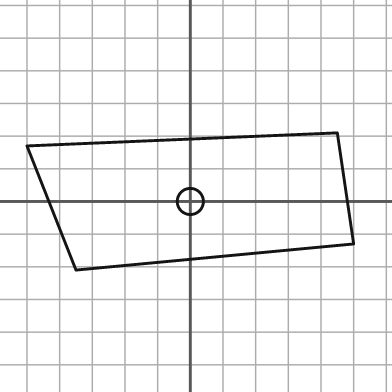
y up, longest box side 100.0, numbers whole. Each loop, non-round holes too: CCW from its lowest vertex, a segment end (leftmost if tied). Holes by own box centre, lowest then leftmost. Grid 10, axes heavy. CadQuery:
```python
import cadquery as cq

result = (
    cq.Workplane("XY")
    .moveTo(-35.0, -21.0)
    .lineTo(50.0, -13.0)
    .lineTo(45.0, 21.0)
    .lineTo(-50.0, 17.0)
    .close()
    .moveTo(0.0, 0.0)
    .circle(4.0)
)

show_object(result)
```